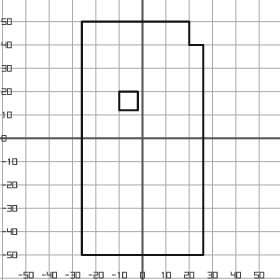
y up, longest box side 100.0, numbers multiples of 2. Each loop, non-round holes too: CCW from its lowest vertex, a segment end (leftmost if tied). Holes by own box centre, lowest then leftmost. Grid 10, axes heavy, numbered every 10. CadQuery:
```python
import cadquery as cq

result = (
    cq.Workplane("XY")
    .moveTo(-26.0, -50.0)
    .lineTo(26.0, -50.0)
    .lineTo(26.0, 40.0)
    .lineTo(20.0, 40.0)
    .lineTo(20.0, 50.0)
    .lineTo(-26.0, 50.0)
    .close()
    .moveTo(-10.0, 12.0)
    .lineTo(-2.0, 12.0)
    .lineTo(-2.0, 20.0)
    .lineTo(-10.0, 20.0)
    .close()
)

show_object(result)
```